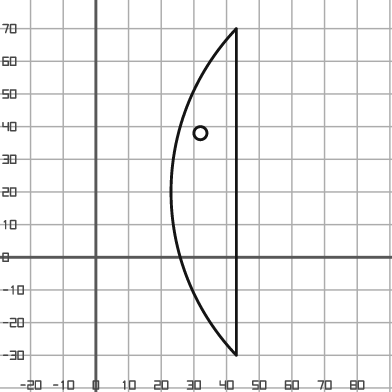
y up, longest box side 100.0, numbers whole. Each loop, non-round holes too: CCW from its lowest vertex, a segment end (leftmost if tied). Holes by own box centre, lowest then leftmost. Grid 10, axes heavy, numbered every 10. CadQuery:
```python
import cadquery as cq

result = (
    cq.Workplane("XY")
    .moveTo(43.0, -30.0)
    .lineTo(43.0, 70.0)
    .threePointArc((23.0, 20.0), (43.0, -30.0))
    .close()
    .moveTo(32.0, 38.0)
    .circle(2.0)
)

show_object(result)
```